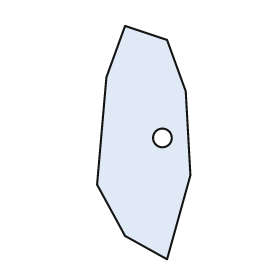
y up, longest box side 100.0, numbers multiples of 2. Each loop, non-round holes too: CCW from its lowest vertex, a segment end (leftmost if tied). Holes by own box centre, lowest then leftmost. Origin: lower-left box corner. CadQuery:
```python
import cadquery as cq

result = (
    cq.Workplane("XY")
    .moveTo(30.0, 0.0)
    .lineTo(40.0, 36.0)
    .lineTo(38.0, 72.0)
    .lineTo(30.0, 94.0)
    .lineTo(12.0, 100.0)
    .lineTo(4.0, 78.0)
    .lineTo(0.0, 32.0)
    .lineTo(12.0, 10.0)
    .close()
    .moveTo(28.0, 52.0)
    .circle(4.0)
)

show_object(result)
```